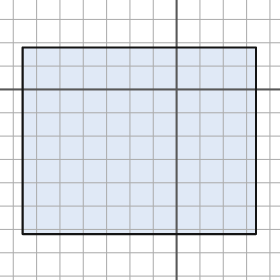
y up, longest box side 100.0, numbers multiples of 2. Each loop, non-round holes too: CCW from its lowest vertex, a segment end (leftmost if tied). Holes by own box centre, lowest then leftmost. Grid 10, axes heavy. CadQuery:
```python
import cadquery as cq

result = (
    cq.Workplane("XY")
    .moveTo(-66.0, -62.0)
    .lineTo(34.0, -62.0)
    .lineTo(34.0, 18.0)
    .lineTo(-66.0, 18.0)
    .close()
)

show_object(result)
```